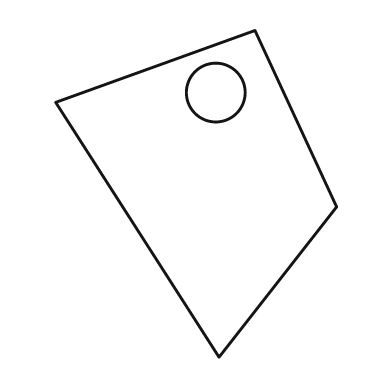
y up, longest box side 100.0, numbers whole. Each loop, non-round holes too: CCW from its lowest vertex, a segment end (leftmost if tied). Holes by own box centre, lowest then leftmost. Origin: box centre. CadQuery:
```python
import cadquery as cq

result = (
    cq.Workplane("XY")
    .moveTo(7.0, -50.0)
    .lineTo(43.0, -4.0)
    .lineTo(18.0, 50.0)
    .lineTo(-43.0, 28.0)
    .close()
    .moveTo(6.0, 31.0)
    .circle(9.0)
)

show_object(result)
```